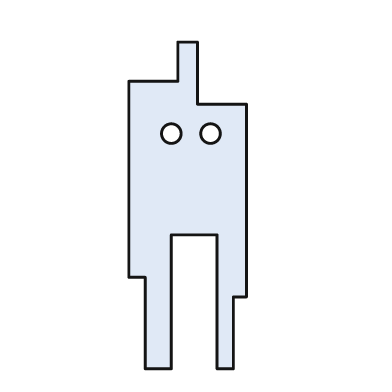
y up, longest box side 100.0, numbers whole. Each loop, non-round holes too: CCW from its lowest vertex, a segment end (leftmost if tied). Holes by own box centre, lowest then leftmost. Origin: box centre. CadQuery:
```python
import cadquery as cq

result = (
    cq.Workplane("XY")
    .moveTo(-13.0, -50.0)
    .lineTo(-5.0, -50.0)
    .lineTo(-5.0, -9.0)
    .lineTo(9.0, -9.0)
    .lineTo(9.0, -50.0)
    .lineTo(14.0, -50.0)
    .lineTo(14.0, -28.0)
    .lineTo(18.0, -28.0)
    .lineTo(18.0, 31.0)
    .lineTo(3.0, 31.0)
    .lineTo(3.0, 50.0)
    .lineTo(-3.0, 50.0)
    .lineTo(-3.0, 38.0)
    .lineTo(-18.0, 38.0)
    .lineTo(-18.0, -22.0)
    .lineTo(-13.0, -22.0)
    .close()
    .moveTo(-5.0, 22.0)
    .circle(3.0)
    .moveTo(7.0, 22.0)
    .circle(3.0)
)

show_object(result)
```